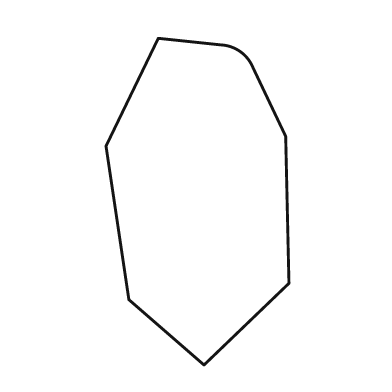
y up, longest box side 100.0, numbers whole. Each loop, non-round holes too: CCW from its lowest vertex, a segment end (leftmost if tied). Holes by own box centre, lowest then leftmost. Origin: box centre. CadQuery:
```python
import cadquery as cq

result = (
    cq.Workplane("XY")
    .moveTo(2.0, -50.0)
    .lineTo(28.0, -25.0)
    .lineTo(27.0, 20.0)
    .lineTo(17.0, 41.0)
    .threePointArc((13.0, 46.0), (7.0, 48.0))
    .lineTo(-12.0, 50.0)
    .lineTo(-28.0, 17.0)
    .lineTo(-21.0, -30.0)
    .close()
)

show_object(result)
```